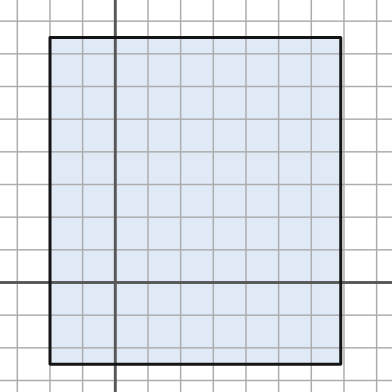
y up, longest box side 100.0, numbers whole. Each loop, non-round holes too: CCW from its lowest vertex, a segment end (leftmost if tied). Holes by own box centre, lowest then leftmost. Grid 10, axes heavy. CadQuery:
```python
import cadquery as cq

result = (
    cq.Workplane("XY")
    .moveTo(-20.0, -25.0)
    .lineTo(69.0, -25.0)
    .lineTo(69.0, 75.0)
    .lineTo(-20.0, 75.0)
    .close()
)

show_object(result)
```